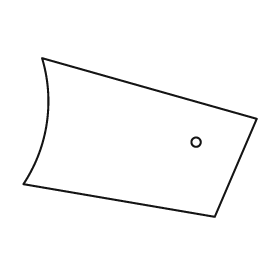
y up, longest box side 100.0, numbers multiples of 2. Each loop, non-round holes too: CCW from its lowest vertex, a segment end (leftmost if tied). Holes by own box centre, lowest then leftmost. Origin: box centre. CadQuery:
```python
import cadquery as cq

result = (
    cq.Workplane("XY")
    .moveTo(32.0, -34.0)
    .lineTo(50.0, 8.0)
    .lineTo(-42.0, 34.0)
    .threePointArc((-40.0, 6.0), (-50.0, -20.0))
    .close()
    .moveTo(24.0, -2.0)
    .circle(2.0)
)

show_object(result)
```